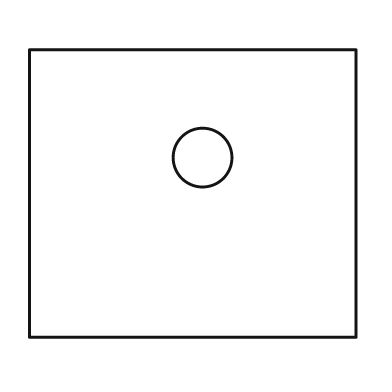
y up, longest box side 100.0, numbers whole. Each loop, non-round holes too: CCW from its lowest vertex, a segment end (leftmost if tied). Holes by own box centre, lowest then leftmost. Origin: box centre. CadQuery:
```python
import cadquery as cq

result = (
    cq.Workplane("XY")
    .moveTo(-50.0, -44.0)
    .lineTo(50.0, -44.0)
    .lineTo(50.0, 44.0)
    .lineTo(-50.0, 44.0)
    .close()
    .moveTo(3.0, 11.0)
    .circle(9.0)
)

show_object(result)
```